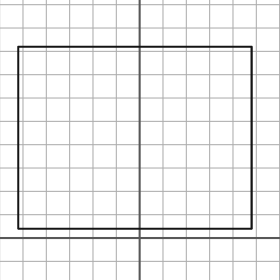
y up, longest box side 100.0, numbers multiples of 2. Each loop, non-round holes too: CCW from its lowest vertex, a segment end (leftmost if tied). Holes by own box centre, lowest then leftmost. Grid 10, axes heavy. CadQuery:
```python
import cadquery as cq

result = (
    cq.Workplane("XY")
    .moveTo(-52.0, 4.0)
    .lineTo(48.0, 4.0)
    .lineTo(48.0, 82.0)
    .lineTo(-52.0, 82.0)
    .close()
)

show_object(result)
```